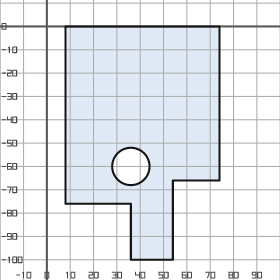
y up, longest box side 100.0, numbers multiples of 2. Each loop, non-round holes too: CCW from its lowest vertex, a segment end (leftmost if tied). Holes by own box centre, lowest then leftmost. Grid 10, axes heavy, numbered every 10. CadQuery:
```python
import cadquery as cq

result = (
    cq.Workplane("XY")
    .moveTo(36.0, -100.0)
    .lineTo(54.0, -100.0)
    .lineTo(54.0, -66.0)
    .lineTo(74.0, -66.0)
    .lineTo(74.0, 0.0)
    .lineTo(8.0, 0.0)
    .lineTo(8.0, -76.0)
    .lineTo(36.0, -76.0)
    .close()
    .moveTo(36.0, -60.0)
    .circle(8.0)
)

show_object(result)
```